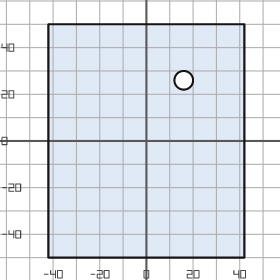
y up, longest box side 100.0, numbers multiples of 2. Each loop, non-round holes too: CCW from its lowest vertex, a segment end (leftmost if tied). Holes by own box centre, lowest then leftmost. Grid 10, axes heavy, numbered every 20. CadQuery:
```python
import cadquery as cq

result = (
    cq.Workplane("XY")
    .moveTo(-42.0, -50.0)
    .lineTo(42.0, -50.0)
    .lineTo(42.0, 50.0)
    .lineTo(-42.0, 50.0)
    .close()
    .moveTo(16.0, 26.0)
    .circle(4.0)
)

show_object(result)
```